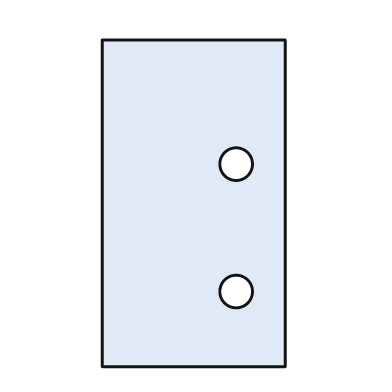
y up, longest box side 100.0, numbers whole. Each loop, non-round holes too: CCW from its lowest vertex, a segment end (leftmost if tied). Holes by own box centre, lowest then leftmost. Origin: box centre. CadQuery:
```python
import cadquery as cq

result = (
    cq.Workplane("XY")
    .moveTo(-28.0, -50.0)
    .lineTo(28.0, -50.0)
    .lineTo(28.0, 50.0)
    .lineTo(-28.0, 50.0)
    .close()
    .moveTo(13.0, -27.0)
    .circle(5.0)
    .moveTo(13.0, 12.0)
    .circle(5.0)
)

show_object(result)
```